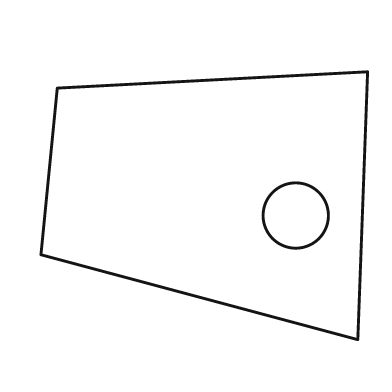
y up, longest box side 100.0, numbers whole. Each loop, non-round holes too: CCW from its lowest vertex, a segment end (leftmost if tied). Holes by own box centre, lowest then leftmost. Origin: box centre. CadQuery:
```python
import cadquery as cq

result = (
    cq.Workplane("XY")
    .moveTo(47.0, -41.0)
    .lineTo(50.0, 41.0)
    .lineTo(-45.0, 36.0)
    .lineTo(-50.0, -15.0)
    .close()
    .moveTo(28.0, -3.0)
    .circle(10.0)
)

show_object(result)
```